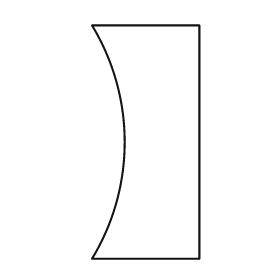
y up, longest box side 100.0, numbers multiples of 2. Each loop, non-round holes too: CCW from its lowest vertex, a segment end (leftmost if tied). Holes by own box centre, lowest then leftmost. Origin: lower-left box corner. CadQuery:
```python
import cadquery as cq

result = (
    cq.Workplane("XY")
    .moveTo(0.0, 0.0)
    .lineTo(46.0, 0.0)
    .lineTo(46.0, 100.0)
    .lineTo(0.0, 100.0)
    .threePointArc((14.0, 50.0), (0.0, 0.0))
    .close()
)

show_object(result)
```